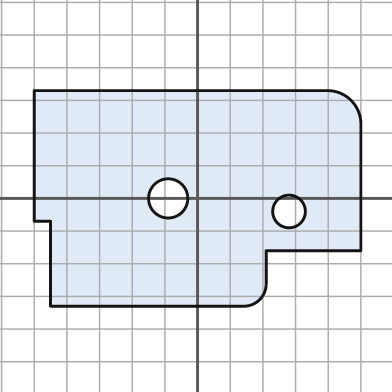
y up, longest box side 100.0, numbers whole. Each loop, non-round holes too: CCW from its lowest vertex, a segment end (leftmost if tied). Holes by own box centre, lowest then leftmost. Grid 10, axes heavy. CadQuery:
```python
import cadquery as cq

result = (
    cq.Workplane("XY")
    .moveTo(-45.0, -33.0)
    .lineTo(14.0, -33.0)
    .threePointArc((19.0, -31.0), (21.0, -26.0))
    .lineTo(21.0, -16.0)
    .lineTo(50.0, -16.0)
    .lineTo(50.0, 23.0)
    .threePointArc((47.0, 30.0), (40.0, 33.0))
    .lineTo(-50.0, 33.0)
    .lineTo(-50.0, -7.0)
    .lineTo(-45.0, -7.0)
    .close()
    .moveTo(28.0, -4.0)
    .circle(5.0)
    .moveTo(-9.0, 0.0)
    .circle(6.0)
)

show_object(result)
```